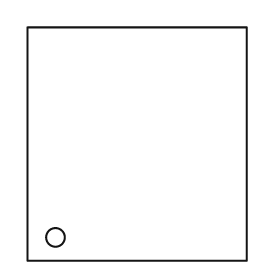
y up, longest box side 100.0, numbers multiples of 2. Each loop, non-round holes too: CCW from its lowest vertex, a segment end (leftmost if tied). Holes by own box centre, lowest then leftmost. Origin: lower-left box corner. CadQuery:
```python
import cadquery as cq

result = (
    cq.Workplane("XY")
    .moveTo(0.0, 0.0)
    .lineTo(94.0, 0.0)
    .lineTo(94.0, 100.0)
    .lineTo(0.0, 100.0)
    .close()
    .moveTo(12.0, 10.0)
    .circle(4.0)
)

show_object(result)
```